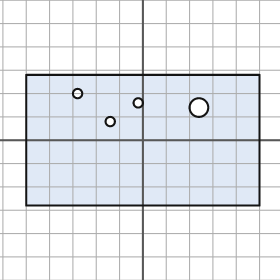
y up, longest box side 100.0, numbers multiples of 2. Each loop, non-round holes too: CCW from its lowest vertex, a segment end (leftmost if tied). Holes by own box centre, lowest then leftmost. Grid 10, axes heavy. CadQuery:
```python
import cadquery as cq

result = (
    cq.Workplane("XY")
    .moveTo(-50.0, -28.0)
    .lineTo(50.0, -28.0)
    .lineTo(50.0, 28.0)
    .lineTo(-50.0, 28.0)
    .close()
    .moveTo(-14.0, 8.0)
    .circle(2.0)
    .moveTo(24.0, 14.0)
    .circle(4.0)
    .moveTo(-2.0, 16.0)
    .circle(2.0)
    .moveTo(-28.0, 20.0)
    .circle(2.0)
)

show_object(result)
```